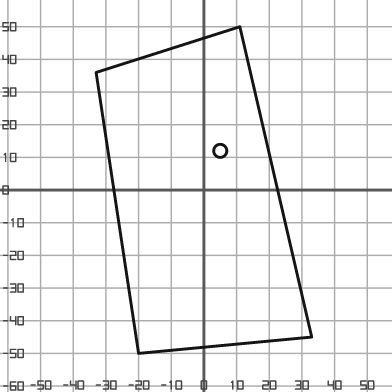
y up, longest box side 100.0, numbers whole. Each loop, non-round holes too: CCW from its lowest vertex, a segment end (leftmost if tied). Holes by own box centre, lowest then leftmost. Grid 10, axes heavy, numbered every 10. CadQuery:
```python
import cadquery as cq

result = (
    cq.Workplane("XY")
    .moveTo(-20.0, -50.0)
    .lineTo(33.0, -45.0)
    .lineTo(11.0, 50.0)
    .lineTo(-33.0, 36.0)
    .close()
    .moveTo(5.0, 12.0)
    .circle(2.0)
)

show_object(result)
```